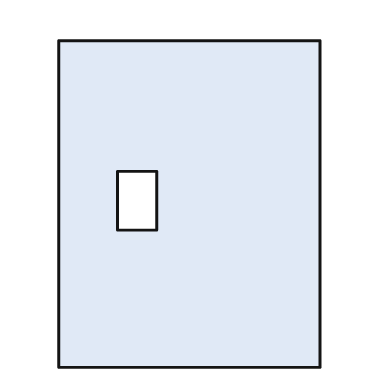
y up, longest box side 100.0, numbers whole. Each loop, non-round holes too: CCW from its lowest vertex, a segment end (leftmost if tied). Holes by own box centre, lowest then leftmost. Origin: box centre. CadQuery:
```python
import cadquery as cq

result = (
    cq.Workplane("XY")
    .moveTo(-40.0, -50.0)
    .lineTo(40.0, -50.0)
    .lineTo(40.0, 50.0)
    .lineTo(-40.0, 50.0)
    .close()
    .moveTo(-22.0, -8.0)
    .lineTo(-10.0, -8.0)
    .lineTo(-10.0, 10.0)
    .lineTo(-22.0, 10.0)
    .close()
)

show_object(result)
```